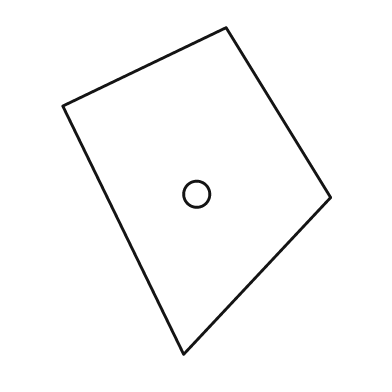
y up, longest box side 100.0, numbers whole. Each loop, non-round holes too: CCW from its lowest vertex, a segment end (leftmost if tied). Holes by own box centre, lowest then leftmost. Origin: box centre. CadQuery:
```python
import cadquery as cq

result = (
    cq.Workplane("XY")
    .moveTo(-4.0, -50.0)
    .lineTo(41.0, -2.0)
    .lineTo(9.0, 50.0)
    .lineTo(-41.0, 26.0)
    .close()
    .moveTo(0.0, -1.0)
    .circle(4.0)
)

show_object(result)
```